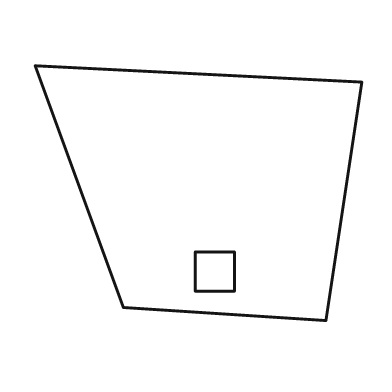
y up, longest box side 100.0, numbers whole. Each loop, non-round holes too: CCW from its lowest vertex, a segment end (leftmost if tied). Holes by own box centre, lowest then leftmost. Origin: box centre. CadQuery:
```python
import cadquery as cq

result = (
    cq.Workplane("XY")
    .moveTo(39.0, -39.0)
    .lineTo(50.0, 34.0)
    .lineTo(-50.0, 39.0)
    .lineTo(-23.0, -35.0)
    .close()
    .moveTo(-1.0, -30.0)
    .lineTo(11.0, -30.0)
    .lineTo(11.0, -18.0)
    .lineTo(-1.0, -18.0)
    .close()
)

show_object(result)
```